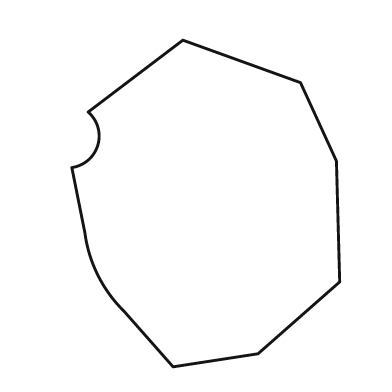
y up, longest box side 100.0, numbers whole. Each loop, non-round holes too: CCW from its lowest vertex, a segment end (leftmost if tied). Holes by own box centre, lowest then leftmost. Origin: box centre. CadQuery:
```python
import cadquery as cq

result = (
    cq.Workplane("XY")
    .moveTo(-10.0, -50.0)
    .lineTo(16.0, -46.0)
    .lineTo(41.0, -24.0)
    .lineTo(40.0, 13.0)
    .lineTo(29.0, 37.0)
    .lineTo(-7.0, 50.0)
    .lineTo(-36.0, 28.0)
    .threePointArc((-33.0, 18.0), (-41.0, 11.0))
    .lineTo(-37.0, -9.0)
    .threePointArc((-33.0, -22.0), (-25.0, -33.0))
    .close()
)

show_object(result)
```